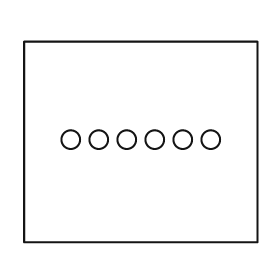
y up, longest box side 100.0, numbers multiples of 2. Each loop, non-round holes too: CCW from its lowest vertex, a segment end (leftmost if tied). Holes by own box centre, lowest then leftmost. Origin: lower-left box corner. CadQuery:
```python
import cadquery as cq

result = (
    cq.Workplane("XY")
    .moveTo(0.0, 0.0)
    .lineTo(100.0, 0.0)
    .lineTo(100.0, 86.0)
    .lineTo(0.0, 86.0)
    .close()
    .moveTo(20.0, 44.0)
    .circle(4.0)
    .moveTo(32.0, 44.0)
    .circle(4.0)
    .moveTo(44.0, 44.0)
    .circle(4.0)
    .moveTo(56.0, 44.0)
    .circle(4.0)
    .moveTo(68.0, 44.0)
    .circle(4.0)
    .moveTo(80.0, 44.0)
    .circle(4.0)
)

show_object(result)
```